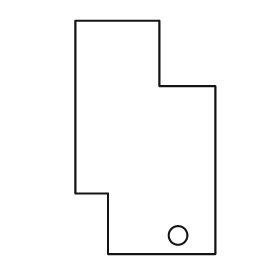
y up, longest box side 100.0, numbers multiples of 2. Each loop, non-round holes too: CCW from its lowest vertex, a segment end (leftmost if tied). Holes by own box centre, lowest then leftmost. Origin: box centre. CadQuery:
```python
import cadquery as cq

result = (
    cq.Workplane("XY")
    .moveTo(-16.0, -50.0)
    .lineTo(30.0, -50.0)
    .lineTo(30.0, 22.0)
    .lineTo(6.0, 22.0)
    .lineTo(6.0, 50.0)
    .lineTo(-30.0, 50.0)
    .lineTo(-30.0, -24.0)
    .lineTo(-16.0, -24.0)
    .close()
    .moveTo(14.0, -42.0)
    .circle(4.0)
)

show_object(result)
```